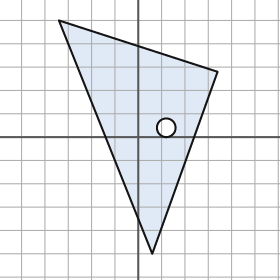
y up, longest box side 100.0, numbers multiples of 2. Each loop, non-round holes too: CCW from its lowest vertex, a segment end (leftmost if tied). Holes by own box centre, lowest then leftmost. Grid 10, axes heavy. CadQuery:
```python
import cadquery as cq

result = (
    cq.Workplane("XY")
    .moveTo(6.0, -50.0)
    .lineTo(34.0, 28.0)
    .lineTo(-34.0, 50.0)
    .close()
    .moveTo(12.0, 4.0)
    .circle(4.0)
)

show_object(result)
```